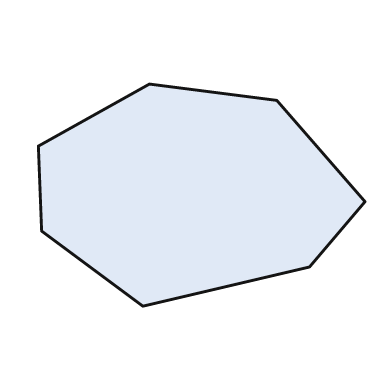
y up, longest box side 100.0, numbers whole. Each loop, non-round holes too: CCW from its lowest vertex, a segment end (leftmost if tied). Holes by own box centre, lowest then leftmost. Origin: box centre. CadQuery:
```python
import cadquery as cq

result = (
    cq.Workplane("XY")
    .moveTo(-18.0, -34.0)
    .lineTo(33.0, -22.0)
    .lineTo(50.0, -2.0)
    .lineTo(23.0, 29.0)
    .lineTo(-16.0, 34.0)
    .lineTo(-50.0, 15.0)
    .lineTo(-49.0, -11.0)
    .close()
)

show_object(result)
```